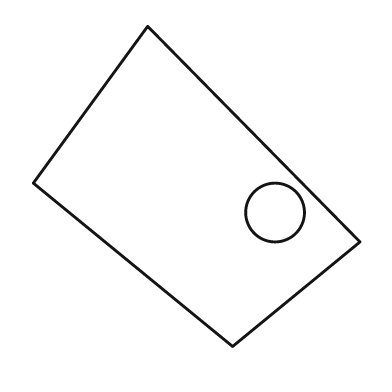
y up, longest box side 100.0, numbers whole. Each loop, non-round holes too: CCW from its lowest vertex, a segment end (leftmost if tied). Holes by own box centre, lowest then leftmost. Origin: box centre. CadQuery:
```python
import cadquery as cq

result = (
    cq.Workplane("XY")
    .moveTo(11.0, -49.0)
    .lineTo(50.0, -17.0)
    .lineTo(-15.0, 49.0)
    .lineTo(-50.0, 1.0)
    .close()
    .moveTo(24.0, -8.0)
    .circle(9.0)
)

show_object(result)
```